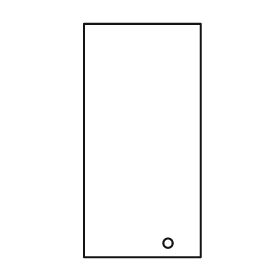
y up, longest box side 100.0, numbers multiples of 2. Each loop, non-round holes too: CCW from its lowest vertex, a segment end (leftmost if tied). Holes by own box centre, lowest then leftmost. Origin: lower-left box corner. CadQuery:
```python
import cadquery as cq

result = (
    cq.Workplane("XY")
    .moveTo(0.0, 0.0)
    .lineTo(50.0, 0.0)
    .lineTo(50.0, 100.0)
    .lineTo(0.0, 100.0)
    .close()
    .moveTo(36.0, 6.0)
    .circle(2.0)
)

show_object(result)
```